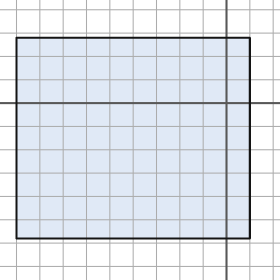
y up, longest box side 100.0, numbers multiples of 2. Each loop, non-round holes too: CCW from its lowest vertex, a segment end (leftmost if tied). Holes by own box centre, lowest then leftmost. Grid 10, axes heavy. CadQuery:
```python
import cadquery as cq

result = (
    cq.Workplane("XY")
    .moveTo(-90.0, -58.0)
    .lineTo(10.0, -58.0)
    .lineTo(10.0, 28.0)
    .lineTo(-90.0, 28.0)
    .close()
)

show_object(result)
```